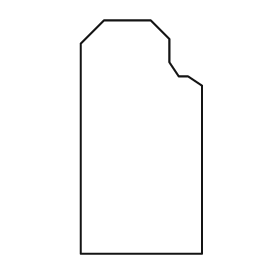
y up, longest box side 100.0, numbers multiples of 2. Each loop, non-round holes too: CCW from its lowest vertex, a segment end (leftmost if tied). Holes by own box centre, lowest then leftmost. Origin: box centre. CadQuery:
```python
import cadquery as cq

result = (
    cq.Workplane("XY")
    .moveTo(-26.0, -50.0)
    .lineTo(26.0, -50.0)
    .lineTo(26.0, 22.0)
    .lineTo(20.0, 26.0)
    .lineTo(16.0, 26.0)
    .lineTo(12.0, 32.0)
    .lineTo(12.0, 42.0)
    .lineTo(4.0, 50.0)
    .lineTo(-16.0, 50.0)
    .lineTo(-26.0, 40.0)
    .close()
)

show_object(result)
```